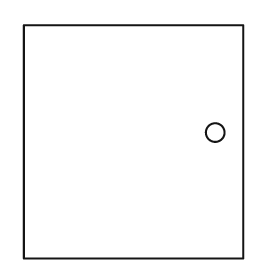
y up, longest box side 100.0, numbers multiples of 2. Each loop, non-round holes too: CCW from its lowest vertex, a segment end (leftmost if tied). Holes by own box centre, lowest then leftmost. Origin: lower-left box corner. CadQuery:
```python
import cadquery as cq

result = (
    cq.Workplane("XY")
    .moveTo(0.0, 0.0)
    .lineTo(94.0, 0.0)
    .lineTo(94.0, 100.0)
    .lineTo(0.0, 100.0)
    .close()
    .moveTo(82.0, 54.0)
    .circle(4.0)
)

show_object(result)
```